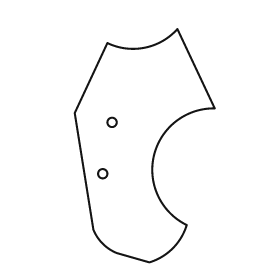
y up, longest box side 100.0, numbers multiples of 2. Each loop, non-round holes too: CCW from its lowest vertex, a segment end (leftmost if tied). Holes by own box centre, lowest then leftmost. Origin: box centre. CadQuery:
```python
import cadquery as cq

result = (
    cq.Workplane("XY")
    .moveTo(2.0, -50.0)
    .threePointArc((12.0, -44.0), (18.0, -34.0))
    .threePointArc((4.0, -4.0), (30.0, 16.0))
    .lineTo(14.0, 50.0)
    .threePointArc((0.0, 42.0), (-16.0, 44.0))
    .lineTo(-30.0, 14.0)
    .lineTo(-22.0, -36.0)
    .threePointArc((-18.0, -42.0), (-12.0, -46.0))
    .close()
    .moveTo(-18.0, -12.0)
    .circle(2.0)
    .moveTo(-14.0, 10.0)
    .circle(2.0)
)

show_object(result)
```